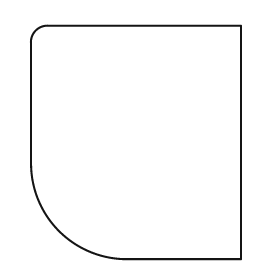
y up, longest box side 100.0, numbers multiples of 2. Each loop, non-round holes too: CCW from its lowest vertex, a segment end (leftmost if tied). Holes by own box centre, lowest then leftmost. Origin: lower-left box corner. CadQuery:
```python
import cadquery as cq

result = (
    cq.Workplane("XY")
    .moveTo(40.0, 0.0)
    .lineTo(90.0, 0.0)
    .lineTo(90.0, 100.0)
    .lineTo(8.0, 100.0)
    .threePointArc((2.0, 98.0), (0.0, 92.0))
    .lineTo(0.0, 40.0)
    .threePointArc((12.0, 12.0), (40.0, 0.0))
    .close()
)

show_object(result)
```